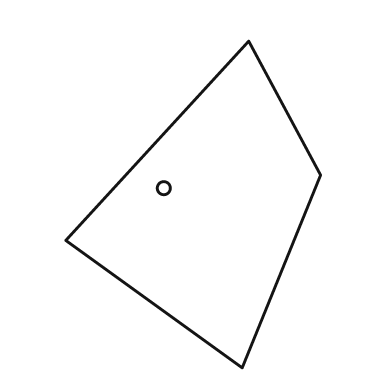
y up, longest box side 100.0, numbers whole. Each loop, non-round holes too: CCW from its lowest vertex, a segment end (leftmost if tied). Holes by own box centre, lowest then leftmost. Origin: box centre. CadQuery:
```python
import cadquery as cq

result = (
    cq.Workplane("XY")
    .moveTo(15.0, -50.0)
    .lineTo(39.0, 9.0)
    .lineTo(17.0, 50.0)
    .lineTo(-39.0, -11.0)
    .close()
    .moveTo(-9.0, 5.0)
    .circle(2.0)
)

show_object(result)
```